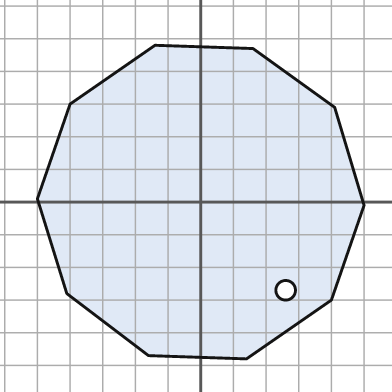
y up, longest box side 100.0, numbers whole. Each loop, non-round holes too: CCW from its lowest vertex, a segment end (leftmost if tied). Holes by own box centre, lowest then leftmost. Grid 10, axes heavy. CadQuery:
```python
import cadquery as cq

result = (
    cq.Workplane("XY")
    .moveTo(14.0, -48.0)
    .lineTo(40.0, -30.0)
    .lineTo(50.0, -1.0)
    .lineTo(41.0, 29.0)
    .lineTo(16.0, 47.0)
    .lineTo(-14.0, 48.0)
    .lineTo(-40.0, 30.0)
    .lineTo(-50.0, 1.0)
    .lineTo(-41.0, -28.0)
    .lineTo(-16.0, -47.0)
    .close()
    .moveTo(26.0, -27.0)
    .circle(3.0)
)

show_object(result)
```